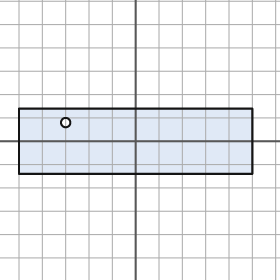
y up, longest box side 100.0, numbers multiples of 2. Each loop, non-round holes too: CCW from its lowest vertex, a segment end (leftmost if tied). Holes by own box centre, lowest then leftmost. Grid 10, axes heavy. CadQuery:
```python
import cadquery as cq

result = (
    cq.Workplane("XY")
    .moveTo(-50.0, -14.0)
    .lineTo(50.0, -14.0)
    .lineTo(50.0, 14.0)
    .lineTo(-50.0, 14.0)
    .close()
    .moveTo(-30.0, 8.0)
    .circle(2.0)
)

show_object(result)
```